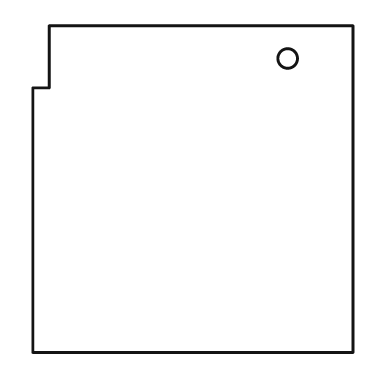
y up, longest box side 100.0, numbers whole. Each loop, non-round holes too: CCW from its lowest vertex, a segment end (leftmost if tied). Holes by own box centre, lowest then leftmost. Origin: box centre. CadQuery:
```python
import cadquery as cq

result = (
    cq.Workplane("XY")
    .moveTo(-49.0, -50.0)
    .lineTo(49.0, -50.0)
    .lineTo(49.0, 50.0)
    .lineTo(-44.0, 50.0)
    .lineTo(-44.0, 31.0)
    .lineTo(-49.0, 31.0)
    .close()
    .moveTo(29.0, 40.0)
    .circle(3.0)
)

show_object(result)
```